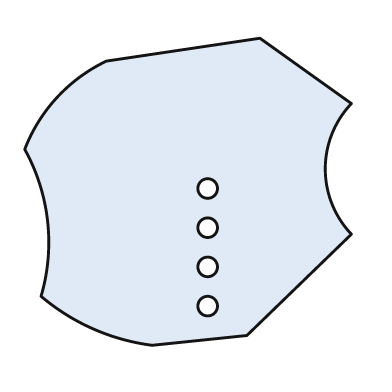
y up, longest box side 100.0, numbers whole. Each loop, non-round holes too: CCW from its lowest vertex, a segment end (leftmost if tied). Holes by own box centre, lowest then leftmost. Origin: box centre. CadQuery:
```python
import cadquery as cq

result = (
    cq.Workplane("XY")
    .moveTo(-11.0, -47.0)
    .lineTo(18.0, -44.0)
    .lineTo(50.0, -13.0)
    .threePointArc((42.0, 7.0), (50.0, 27.0))
    .lineTo(22.0, 47.0)
    .lineTo(-25.0, 40.0)
    .threePointArc((-40.0, 29.0), (-50.0, 13.0))
    .threePointArc((-43.0, -9.0), (-45.0, -32.0))
    .threePointArc((-29.0, -42.0), (-11.0, -47.0))
    .close()
    .moveTo(6.0, -35.0)
    .circle(3.0)
    .moveTo(6.0, -23.0)
    .circle(3.0)
    .moveTo(6.0, -11.0)
    .circle(3.0)
    .moveTo(6.0, 1.0)
    .circle(3.0)
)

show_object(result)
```